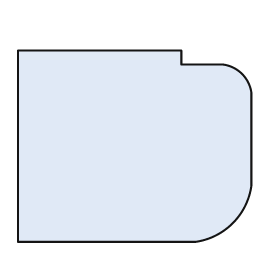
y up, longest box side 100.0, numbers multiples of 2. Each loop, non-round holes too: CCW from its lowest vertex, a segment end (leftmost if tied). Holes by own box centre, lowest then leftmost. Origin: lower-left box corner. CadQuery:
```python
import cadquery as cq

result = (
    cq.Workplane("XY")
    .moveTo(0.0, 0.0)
    .lineTo(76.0, 0.0)
    .threePointArc((92.0, 8.0), (100.0, 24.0))
    .lineTo(100.0, 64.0)
    .threePointArc((96.0, 72.0), (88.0, 76.0))
    .lineTo(70.0, 76.0)
    .lineTo(70.0, 82.0)
    .lineTo(0.0, 82.0)
    .close()
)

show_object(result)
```